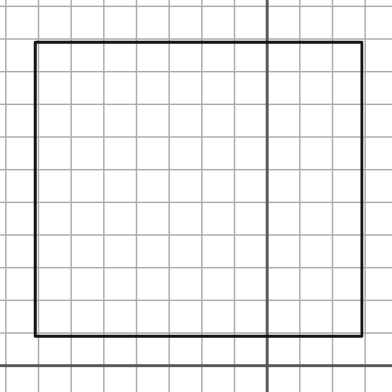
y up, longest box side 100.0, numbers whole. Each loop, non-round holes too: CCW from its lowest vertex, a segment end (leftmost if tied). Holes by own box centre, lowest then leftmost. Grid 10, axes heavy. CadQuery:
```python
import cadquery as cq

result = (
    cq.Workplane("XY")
    .moveTo(-71.0, 9.0)
    .lineTo(29.0, 9.0)
    .lineTo(29.0, 99.0)
    .lineTo(-71.0, 99.0)
    .close()
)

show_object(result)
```